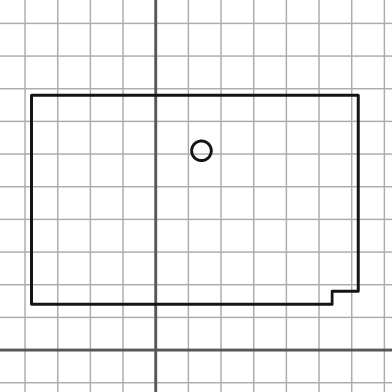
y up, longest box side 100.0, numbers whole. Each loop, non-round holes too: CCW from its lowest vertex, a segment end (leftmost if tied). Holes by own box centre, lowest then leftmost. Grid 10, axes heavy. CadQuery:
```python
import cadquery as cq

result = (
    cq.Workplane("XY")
    .moveTo(-38.0, 14.0)
    .lineTo(54.0, 14.0)
    .lineTo(54.0, 18.0)
    .lineTo(62.0, 18.0)
    .lineTo(62.0, 78.0)
    .lineTo(-38.0, 78.0)
    .close()
    .moveTo(14.0, 61.0)
    .circle(3.0)
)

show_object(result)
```